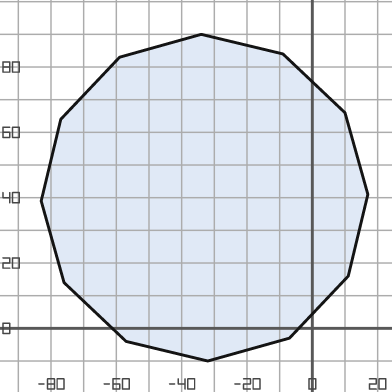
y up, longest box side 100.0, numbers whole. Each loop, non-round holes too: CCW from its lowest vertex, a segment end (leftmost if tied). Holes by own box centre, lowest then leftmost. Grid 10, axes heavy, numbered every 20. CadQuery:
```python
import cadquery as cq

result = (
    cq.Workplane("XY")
    .moveTo(-32.0, -10.0)
    .lineTo(-7.0, -3.0)
    .lineTo(11.0, 16.0)
    .lineTo(17.0, 41.0)
    .lineTo(10.0, 66.0)
    .lineTo(-9.0, 84.0)
    .lineTo(-34.0, 90.0)
    .lineTo(-59.0, 83.0)
    .lineTo(-77.0, 64.0)
    .lineTo(-83.0, 39.0)
    .lineTo(-76.0, 14.0)
    .lineTo(-57.0, -4.0)
    .close()
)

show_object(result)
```